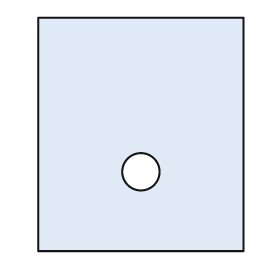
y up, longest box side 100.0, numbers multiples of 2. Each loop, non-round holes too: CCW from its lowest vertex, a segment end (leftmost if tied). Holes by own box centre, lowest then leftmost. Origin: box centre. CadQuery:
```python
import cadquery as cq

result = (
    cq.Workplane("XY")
    .moveTo(-44.0, -50.0)
    .lineTo(44.0, -50.0)
    .lineTo(44.0, 50.0)
    .lineTo(-44.0, 50.0)
    .close()
    .moveTo(0.0, -16.0)
    .circle(8.0)
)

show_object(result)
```